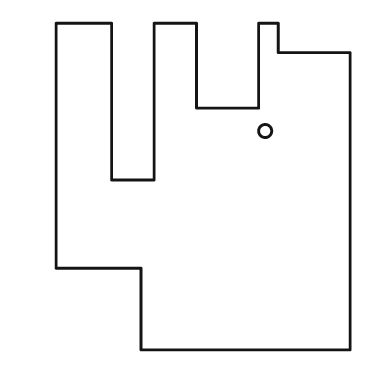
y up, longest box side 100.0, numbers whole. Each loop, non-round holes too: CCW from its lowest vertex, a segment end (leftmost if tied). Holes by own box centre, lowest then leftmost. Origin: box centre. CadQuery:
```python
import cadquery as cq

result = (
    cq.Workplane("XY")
    .moveTo(-19.0, -50.0)
    .lineTo(45.0, -50.0)
    .lineTo(45.0, 41.0)
    .lineTo(23.0, 41.0)
    .lineTo(23.0, 50.0)
    .lineTo(17.0, 50.0)
    .lineTo(17.0, 24.0)
    .lineTo(-2.0, 24.0)
    .lineTo(-2.0, 50.0)
    .lineTo(-15.0, 50.0)
    .lineTo(-15.0, 2.0)
    .lineTo(-28.0, 2.0)
    .lineTo(-28.0, 50.0)
    .lineTo(-45.0, 50.0)
    .lineTo(-45.0, -25.0)
    .lineTo(-19.0, -25.0)
    .close()
    .moveTo(19.0, 17.0)
    .circle(2.0)
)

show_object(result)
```